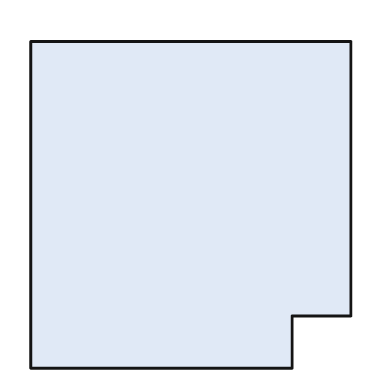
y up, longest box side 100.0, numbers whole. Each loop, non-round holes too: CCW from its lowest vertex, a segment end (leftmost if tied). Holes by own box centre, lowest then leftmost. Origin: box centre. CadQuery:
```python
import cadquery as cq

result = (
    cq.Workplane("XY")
    .moveTo(-49.0, -50.0)
    .lineTo(31.0, -50.0)
    .lineTo(31.0, -34.0)
    .lineTo(49.0, -34.0)
    .lineTo(49.0, 50.0)
    .lineTo(-49.0, 50.0)
    .close()
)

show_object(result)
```